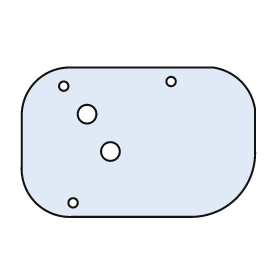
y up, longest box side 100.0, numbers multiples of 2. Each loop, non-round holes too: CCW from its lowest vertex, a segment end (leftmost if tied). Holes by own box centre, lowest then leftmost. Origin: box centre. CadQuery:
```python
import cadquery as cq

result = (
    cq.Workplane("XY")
    .moveTo(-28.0, -32.0)
    .lineTo(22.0, -32.0)
    .threePointArc((42.0, -24.0), (50.0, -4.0))
    .lineTo(50.0, 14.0)
    .threePointArc((44.0, 26.0), (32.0, 32.0))
    .lineTo(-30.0, 32.0)
    .threePointArc((-44.0, 26.0), (-50.0, 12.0))
    .lineTo(-50.0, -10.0)
    .threePointArc((-44.0, -26.0), (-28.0, -32.0))
    .close()
    .moveTo(-28.0, -26.0)
    .circle(2.0)
    .moveTo(-12.0, -4.0)
    .circle(4.0)
    .moveTo(-22.0, 12.0)
    .circle(4.0)
    .moveTo(-32.0, 24.0)
    .circle(2.0)
    .moveTo(14.0, 26.0)
    .circle(2.0)
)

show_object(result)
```